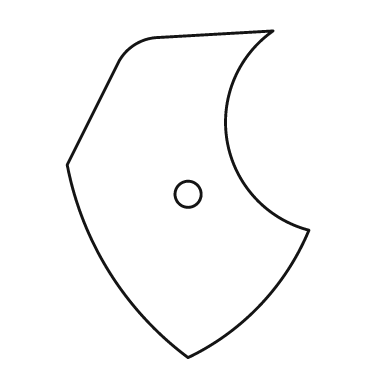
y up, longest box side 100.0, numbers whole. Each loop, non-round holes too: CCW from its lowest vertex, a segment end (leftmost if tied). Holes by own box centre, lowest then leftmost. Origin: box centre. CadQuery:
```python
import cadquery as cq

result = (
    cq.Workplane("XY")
    .moveTo(0.0, -50.0)
    .threePointArc((22.0, -34.0), (37.0, -11.0))
    .threePointArc((12.0, 16.0), (26.0, 50.0))
    .lineTo(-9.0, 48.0)
    .threePointArc((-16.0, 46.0), (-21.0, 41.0))
    .lineTo(-37.0, 9.0)
    .threePointArc((-24.0, -24.0), (0.0, -50.0))
    .close()
    .moveTo(0.0, 0.0)
    .circle(4.0)
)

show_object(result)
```